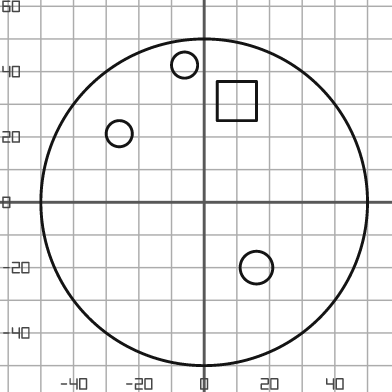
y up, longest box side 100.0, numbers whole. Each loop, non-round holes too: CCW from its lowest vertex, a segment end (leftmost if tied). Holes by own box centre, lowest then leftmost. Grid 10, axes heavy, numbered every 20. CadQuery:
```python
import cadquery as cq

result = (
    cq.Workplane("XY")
    .moveTo(0.0, 0.0)
    .circle(50.0)
    .moveTo(16.0, -20.0)
    .circle(5.0)
    .moveTo(-26.0, 21.0)
    .circle(4.0)
    .moveTo(4.0, 25.0)
    .lineTo(16.0, 25.0)
    .lineTo(16.0, 37.0)
    .lineTo(4.0, 37.0)
    .close()
    .moveTo(-6.0, 42.0)
    .circle(4.0)
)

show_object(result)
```